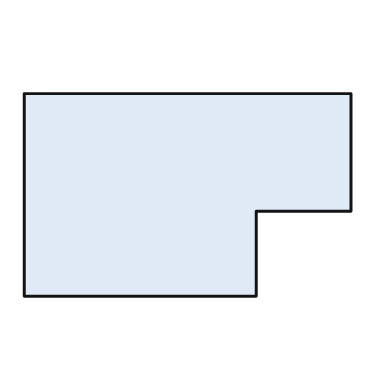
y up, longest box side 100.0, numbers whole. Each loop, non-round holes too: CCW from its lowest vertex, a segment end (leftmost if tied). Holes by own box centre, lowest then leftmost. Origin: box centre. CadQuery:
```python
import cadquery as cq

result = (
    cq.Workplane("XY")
    .moveTo(-50.0, -31.0)
    .lineTo(21.0, -31.0)
    .lineTo(21.0, -5.0)
    .lineTo(50.0, -5.0)
    .lineTo(50.0, 31.0)
    .lineTo(-50.0, 31.0)
    .close()
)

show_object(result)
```